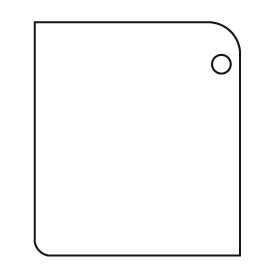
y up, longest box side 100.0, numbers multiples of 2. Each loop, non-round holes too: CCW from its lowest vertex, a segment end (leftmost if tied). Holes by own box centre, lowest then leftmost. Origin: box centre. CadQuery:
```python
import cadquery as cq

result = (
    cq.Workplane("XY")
    .moveTo(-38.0, -50.0)
    .lineTo(44.0, -50.0)
    .lineTo(44.0, 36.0)
    .threePointArc((40.0, 46.0), (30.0, 50.0))
    .lineTo(-44.0, 50.0)
    .lineTo(-44.0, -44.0)
    .threePointArc((-42.0, -48.0), (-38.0, -50.0))
    .close()
    .moveTo(36.0, 32.0)
    .circle(4.0)
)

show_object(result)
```